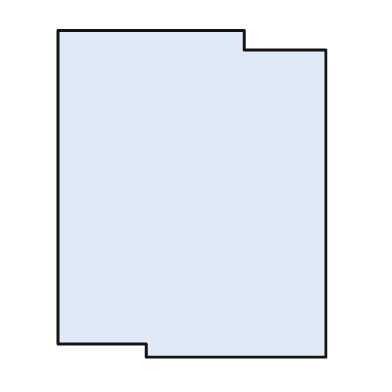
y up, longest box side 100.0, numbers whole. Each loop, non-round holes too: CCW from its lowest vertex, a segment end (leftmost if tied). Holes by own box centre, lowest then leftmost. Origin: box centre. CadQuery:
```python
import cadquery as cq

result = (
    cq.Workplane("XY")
    .moveTo(-14.0, -50.0)
    .lineTo(41.0, -50.0)
    .lineTo(41.0, 44.0)
    .lineTo(16.0, 44.0)
    .lineTo(16.0, 50.0)
    .lineTo(-41.0, 50.0)
    .lineTo(-41.0, -46.0)
    .lineTo(-14.0, -46.0)
    .close()
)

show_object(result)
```